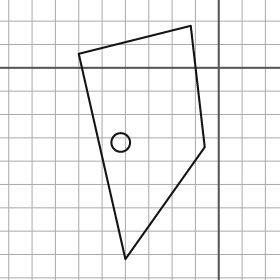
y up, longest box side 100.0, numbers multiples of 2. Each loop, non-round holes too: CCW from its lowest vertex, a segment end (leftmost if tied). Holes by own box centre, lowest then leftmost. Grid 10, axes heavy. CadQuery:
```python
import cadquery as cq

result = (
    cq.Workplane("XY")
    .moveTo(-40.0, -82.0)
    .lineTo(-6.0, -34.0)
    .lineTo(-12.0, 18.0)
    .lineTo(-60.0, 6.0)
    .close()
    .moveTo(-42.0, -32.0)
    .circle(4.0)
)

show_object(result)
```